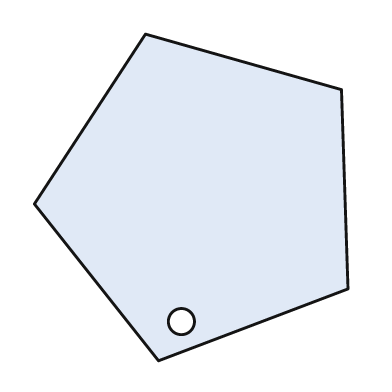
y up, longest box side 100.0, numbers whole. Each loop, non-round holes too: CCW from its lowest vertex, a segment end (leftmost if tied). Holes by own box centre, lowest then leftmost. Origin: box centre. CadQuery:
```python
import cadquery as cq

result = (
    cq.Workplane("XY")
    .moveTo(-10.0, -50.0)
    .lineTo(48.0, -28.0)
    .lineTo(46.0, 33.0)
    .lineTo(-14.0, 50.0)
    .lineTo(-48.0, -2.0)
    .close()
    .moveTo(-3.0, -38.0)
    .circle(4.0)
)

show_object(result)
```